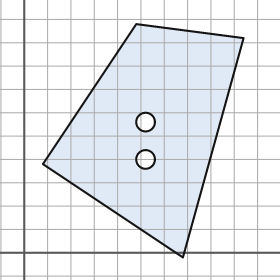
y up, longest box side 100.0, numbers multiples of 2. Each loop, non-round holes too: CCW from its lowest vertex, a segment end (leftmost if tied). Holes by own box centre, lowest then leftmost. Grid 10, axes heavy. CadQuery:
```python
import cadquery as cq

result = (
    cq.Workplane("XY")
    .moveTo(68.0, -2.0)
    .lineTo(94.0, 92.0)
    .lineTo(48.0, 98.0)
    .lineTo(8.0, 38.0)
    .close()
    .moveTo(52.0, 40.0)
    .circle(4.0)
    .moveTo(52.0, 56.0)
    .circle(4.0)
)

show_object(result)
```